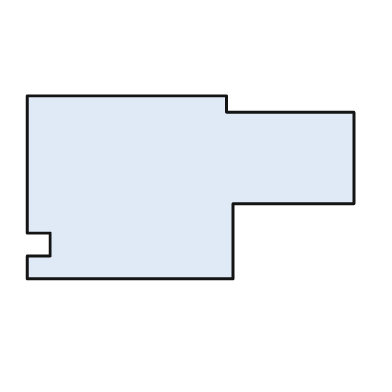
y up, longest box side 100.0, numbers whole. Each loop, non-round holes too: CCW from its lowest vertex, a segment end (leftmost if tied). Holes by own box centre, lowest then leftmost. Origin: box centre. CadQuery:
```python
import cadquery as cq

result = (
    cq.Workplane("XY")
    .moveTo(-50.0, -28.0)
    .lineTo(13.0, -28.0)
    .lineTo(13.0, -5.0)
    .lineTo(50.0, -5.0)
    .lineTo(50.0, 23.0)
    .lineTo(11.0, 23.0)
    .lineTo(11.0, 28.0)
    .lineTo(-50.0, 28.0)
    .lineTo(-50.0, -14.0)
    .lineTo(-43.0, -14.0)
    .lineTo(-43.0, -21.0)
    .lineTo(-50.0, -21.0)
    .close()
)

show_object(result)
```